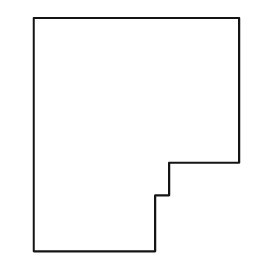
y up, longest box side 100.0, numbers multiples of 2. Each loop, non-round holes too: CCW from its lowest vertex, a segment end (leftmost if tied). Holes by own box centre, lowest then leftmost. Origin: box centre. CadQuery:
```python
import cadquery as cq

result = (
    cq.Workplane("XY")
    .moveTo(-44.0, -50.0)
    .lineTo(8.0, -50.0)
    .lineTo(8.0, -26.0)
    .lineTo(14.0, -26.0)
    .lineTo(14.0, -12.0)
    .lineTo(44.0, -12.0)
    .lineTo(44.0, 50.0)
    .lineTo(-44.0, 50.0)
    .close()
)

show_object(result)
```